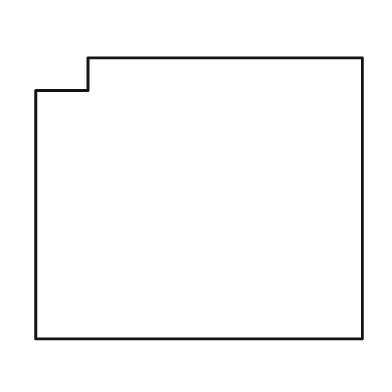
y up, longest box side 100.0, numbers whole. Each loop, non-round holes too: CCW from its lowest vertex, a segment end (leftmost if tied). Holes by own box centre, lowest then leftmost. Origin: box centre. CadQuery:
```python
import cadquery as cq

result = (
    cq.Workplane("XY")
    .moveTo(-50.0, -43.0)
    .lineTo(50.0, -43.0)
    .lineTo(50.0, 43.0)
    .lineTo(-34.0, 43.0)
    .lineTo(-34.0, 33.0)
    .lineTo(-50.0, 33.0)
    .close()
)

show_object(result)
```